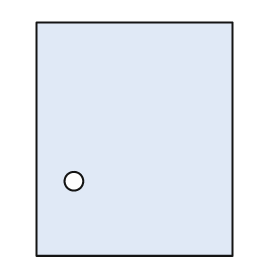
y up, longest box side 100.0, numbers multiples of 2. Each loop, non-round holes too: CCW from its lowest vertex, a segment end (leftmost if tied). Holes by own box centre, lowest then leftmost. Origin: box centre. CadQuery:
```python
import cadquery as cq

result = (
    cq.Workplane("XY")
    .moveTo(-42.0, -50.0)
    .lineTo(42.0, -50.0)
    .lineTo(42.0, 50.0)
    .lineTo(-42.0, 50.0)
    .close()
    .moveTo(-26.0, -18.0)
    .circle(4.0)
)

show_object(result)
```